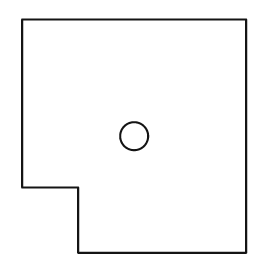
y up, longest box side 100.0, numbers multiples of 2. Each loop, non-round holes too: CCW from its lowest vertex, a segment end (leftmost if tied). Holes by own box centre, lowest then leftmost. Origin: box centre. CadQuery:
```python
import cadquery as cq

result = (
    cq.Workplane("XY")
    .moveTo(-24.0, -50.0)
    .lineTo(48.0, -50.0)
    .lineTo(48.0, 50.0)
    .lineTo(-48.0, 50.0)
    .lineTo(-48.0, -22.0)
    .lineTo(-24.0, -22.0)
    .close()
    .moveTo(0.0, 0.0)
    .circle(6.0)
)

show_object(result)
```